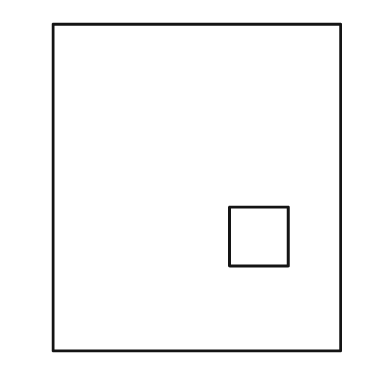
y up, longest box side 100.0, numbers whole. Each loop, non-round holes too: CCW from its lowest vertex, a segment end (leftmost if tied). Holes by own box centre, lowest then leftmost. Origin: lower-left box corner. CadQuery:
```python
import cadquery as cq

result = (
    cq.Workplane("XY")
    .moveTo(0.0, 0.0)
    .lineTo(88.0, 0.0)
    .lineTo(88.0, 100.0)
    .lineTo(0.0, 100.0)
    .close()
    .moveTo(54.0, 26.0)
    .lineTo(72.0, 26.0)
    .lineTo(72.0, 44.0)
    .lineTo(54.0, 44.0)
    .close()
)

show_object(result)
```